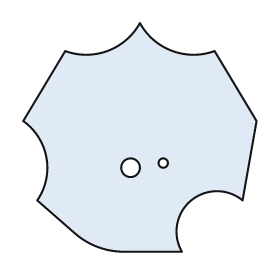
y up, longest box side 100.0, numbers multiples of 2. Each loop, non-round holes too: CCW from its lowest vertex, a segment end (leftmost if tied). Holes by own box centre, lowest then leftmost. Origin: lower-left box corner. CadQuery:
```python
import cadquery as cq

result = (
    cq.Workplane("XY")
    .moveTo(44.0, 0.0)
    .lineTo(68.0, 0.0)
    .threePointArc((72.0, 22.0), (94.0, 22.0))
    .lineTo(100.0, 56.0)
    .lineTo(82.0, 86.0)
    .threePointArc((64.0, 86.0), (50.0, 98.0))
    .threePointArc((36.0, 86.0), (18.0, 86.0))
    .lineTo(0.0, 56.0)
    .threePointArc((10.0, 40.0), (6.0, 22.0))
    .lineTo(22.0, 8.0)
    .threePointArc((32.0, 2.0), (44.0, 0.0))
    .close()
    .moveTo(46.0, 36.0)
    .circle(4.0)
    .moveTo(60.0, 38.0)
    .circle(2.0)
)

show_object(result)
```